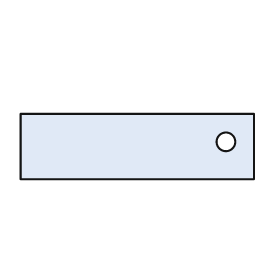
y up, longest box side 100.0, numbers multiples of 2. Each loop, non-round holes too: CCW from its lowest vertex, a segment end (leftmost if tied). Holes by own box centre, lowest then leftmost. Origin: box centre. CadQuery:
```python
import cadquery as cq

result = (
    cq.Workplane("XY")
    .moveTo(-50.0, -14.0)
    .lineTo(50.0, -14.0)
    .lineTo(50.0, 14.0)
    .lineTo(-50.0, 14.0)
    .close()
    .moveTo(38.0, 2.0)
    .circle(4.0)
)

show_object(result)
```